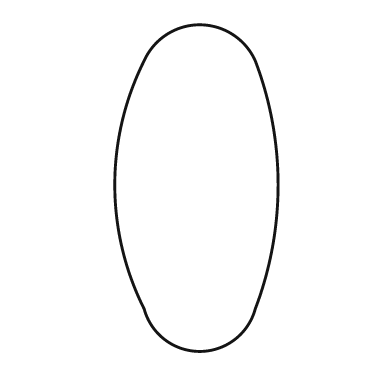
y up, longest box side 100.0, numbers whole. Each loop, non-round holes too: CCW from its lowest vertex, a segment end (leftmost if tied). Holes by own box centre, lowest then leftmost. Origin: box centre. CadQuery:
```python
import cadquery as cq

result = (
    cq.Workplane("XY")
    .moveTo(-16.0, -37.0)
    .threePointArc((1.0, -50.0), (18.0, -37.0))
    .threePointArc((25.0, 1.0), (18.0, 39.0))
    .threePointArc((1.0, 50.0), (-16.0, 39.0))
    .threePointArc((-25.0, 1.0), (-16.0, -37.0))
    .close()
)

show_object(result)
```